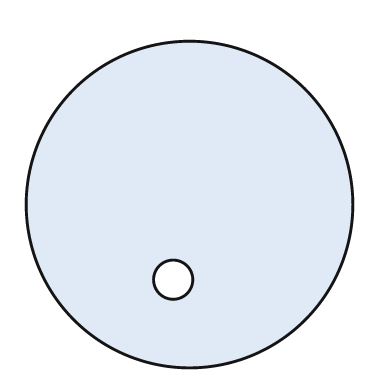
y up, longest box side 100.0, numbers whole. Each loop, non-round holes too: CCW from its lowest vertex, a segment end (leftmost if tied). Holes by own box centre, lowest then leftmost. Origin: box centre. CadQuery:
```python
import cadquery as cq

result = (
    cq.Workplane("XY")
    .moveTo(0.0, 0.0)
    .circle(50.0)
    .moveTo(-5.0, -23.0)
    .circle(6.0)
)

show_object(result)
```